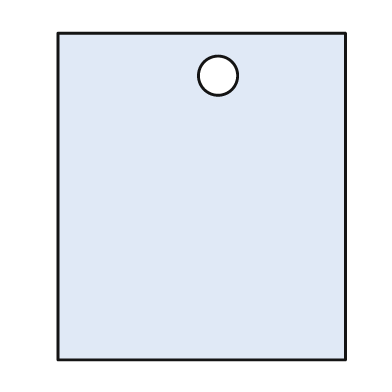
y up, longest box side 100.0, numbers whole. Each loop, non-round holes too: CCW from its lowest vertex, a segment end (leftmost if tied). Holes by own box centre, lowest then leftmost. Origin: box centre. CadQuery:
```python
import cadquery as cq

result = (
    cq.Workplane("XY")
    .moveTo(-44.0, -50.0)
    .lineTo(44.0, -50.0)
    .lineTo(44.0, 50.0)
    .lineTo(-44.0, 50.0)
    .close()
    .moveTo(5.0, 37.0)
    .circle(6.0)
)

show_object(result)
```